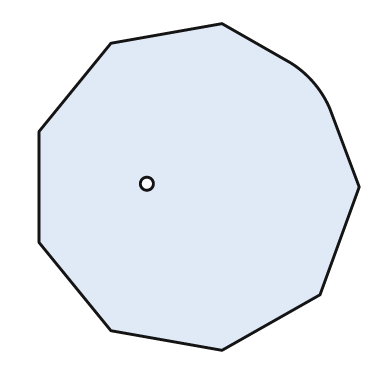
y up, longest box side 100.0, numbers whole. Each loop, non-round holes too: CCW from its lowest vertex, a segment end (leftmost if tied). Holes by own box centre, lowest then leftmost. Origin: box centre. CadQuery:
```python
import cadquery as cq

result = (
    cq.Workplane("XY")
    .moveTo(7.0, -50.0)
    .lineTo(37.0, -33.0)
    .lineTo(49.0, 0.0)
    .lineTo(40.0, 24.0)
    .threePointArc((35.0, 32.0), (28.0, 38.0))
    .lineTo(7.0, 50.0)
    .lineTo(-27.0, 44.0)
    .lineTo(-49.0, 17.0)
    .lineTo(-49.0, -17.0)
    .lineTo(-27.0, -44.0)
    .close()
    .moveTo(-16.0, 1.0)
    .circle(2.0)
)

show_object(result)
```